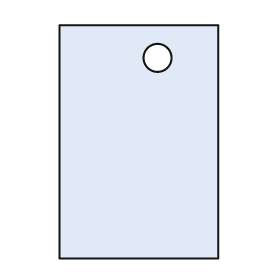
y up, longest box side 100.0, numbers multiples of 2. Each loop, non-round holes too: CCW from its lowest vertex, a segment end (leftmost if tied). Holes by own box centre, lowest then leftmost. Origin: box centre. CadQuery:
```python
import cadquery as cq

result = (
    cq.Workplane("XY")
    .moveTo(-34.0, -50.0)
    .lineTo(34.0, -50.0)
    .lineTo(34.0, 50.0)
    .lineTo(-34.0, 50.0)
    .close()
    .moveTo(8.0, 36.0)
    .circle(6.0)
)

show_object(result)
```